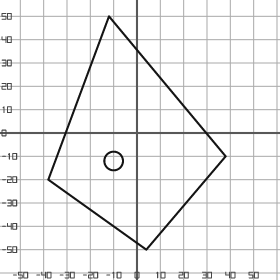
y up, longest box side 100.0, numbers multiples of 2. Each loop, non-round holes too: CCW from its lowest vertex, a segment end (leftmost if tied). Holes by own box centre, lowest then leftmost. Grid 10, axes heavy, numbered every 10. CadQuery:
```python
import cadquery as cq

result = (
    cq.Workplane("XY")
    .moveTo(4.0, -50.0)
    .lineTo(38.0, -10.0)
    .lineTo(-12.0, 50.0)
    .lineTo(-38.0, -20.0)
    .close()
    .moveTo(-10.0, -12.0)
    .circle(4.0)
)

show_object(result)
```